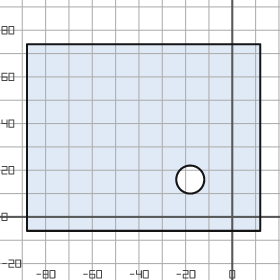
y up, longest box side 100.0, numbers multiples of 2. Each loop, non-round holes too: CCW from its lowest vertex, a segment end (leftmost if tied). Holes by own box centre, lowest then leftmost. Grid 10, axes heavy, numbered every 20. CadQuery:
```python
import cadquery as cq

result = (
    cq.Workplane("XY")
    .moveTo(-88.0, -6.0)
    .lineTo(12.0, -6.0)
    .lineTo(12.0, 74.0)
    .lineTo(-88.0, 74.0)
    .close()
    .moveTo(-18.0, 16.0)
    .circle(6.0)
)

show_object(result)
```